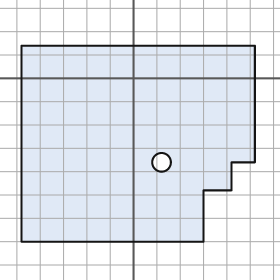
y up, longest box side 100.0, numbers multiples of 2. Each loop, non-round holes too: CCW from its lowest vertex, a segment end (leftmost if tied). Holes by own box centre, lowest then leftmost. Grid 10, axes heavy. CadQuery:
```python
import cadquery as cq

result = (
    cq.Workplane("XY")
    .moveTo(-48.0, -70.0)
    .lineTo(30.0, -70.0)
    .lineTo(30.0, -48.0)
    .lineTo(42.0, -48.0)
    .lineTo(42.0, -36.0)
    .lineTo(52.0, -36.0)
    .lineTo(52.0, 14.0)
    .lineTo(-48.0, 14.0)
    .close()
    .moveTo(12.0, -36.0)
    .circle(4.0)
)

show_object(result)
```